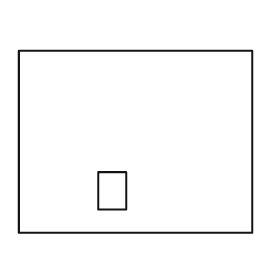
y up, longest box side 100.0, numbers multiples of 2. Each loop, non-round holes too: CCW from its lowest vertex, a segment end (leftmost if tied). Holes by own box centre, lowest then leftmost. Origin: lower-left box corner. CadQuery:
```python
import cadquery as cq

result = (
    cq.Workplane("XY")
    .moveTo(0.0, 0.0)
    .lineTo(100.0, 0.0)
    .lineTo(100.0, 78.0)
    .lineTo(0.0, 78.0)
    .close()
    .moveTo(34.0, 10.0)
    .lineTo(46.0, 10.0)
    .lineTo(46.0, 26.0)
    .lineTo(34.0, 26.0)
    .close()
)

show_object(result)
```